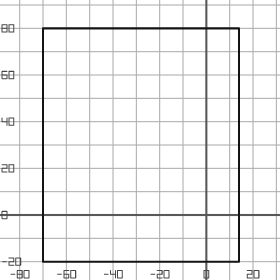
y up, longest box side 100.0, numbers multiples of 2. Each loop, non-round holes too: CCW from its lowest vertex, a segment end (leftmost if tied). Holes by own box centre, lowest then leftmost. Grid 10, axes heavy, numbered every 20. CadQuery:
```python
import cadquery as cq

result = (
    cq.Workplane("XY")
    .moveTo(-70.0, -20.0)
    .lineTo(14.0, -20.0)
    .lineTo(14.0, 80.0)
    .lineTo(-70.0, 80.0)
    .close()
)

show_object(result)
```